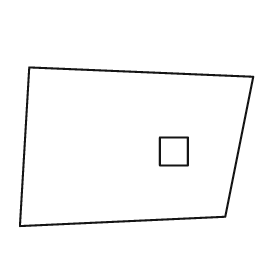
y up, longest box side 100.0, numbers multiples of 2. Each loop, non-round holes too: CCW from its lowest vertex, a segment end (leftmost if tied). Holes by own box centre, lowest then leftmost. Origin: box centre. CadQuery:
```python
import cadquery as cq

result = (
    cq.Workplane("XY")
    .moveTo(-50.0, -34.0)
    .lineTo(38.0, -30.0)
    .lineTo(50.0, 30.0)
    .lineTo(-46.0, 34.0)
    .close()
    .moveTo(10.0, -8.0)
    .lineTo(22.0, -8.0)
    .lineTo(22.0, 4.0)
    .lineTo(10.0, 4.0)
    .close()
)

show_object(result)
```